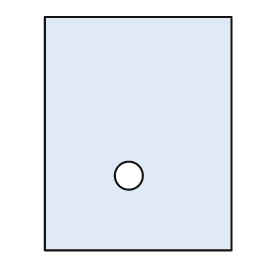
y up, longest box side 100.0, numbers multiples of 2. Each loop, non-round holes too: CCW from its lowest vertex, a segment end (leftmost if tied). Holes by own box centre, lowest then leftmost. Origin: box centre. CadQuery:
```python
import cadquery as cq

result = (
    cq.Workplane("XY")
    .moveTo(-40.0, -50.0)
    .lineTo(40.0, -50.0)
    .lineTo(40.0, 50.0)
    .lineTo(-40.0, 50.0)
    .close()
    .moveTo(-4.0, -18.0)
    .circle(6.0)
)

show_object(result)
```